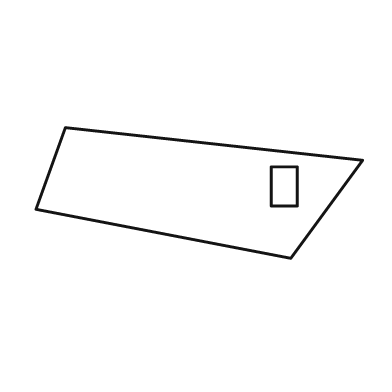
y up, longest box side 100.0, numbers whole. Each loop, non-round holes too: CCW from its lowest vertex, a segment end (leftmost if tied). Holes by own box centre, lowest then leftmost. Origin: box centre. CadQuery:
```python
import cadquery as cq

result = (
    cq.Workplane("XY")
    .moveTo(28.0, -20.0)
    .lineTo(50.0, 10.0)
    .lineTo(-41.0, 20.0)
    .lineTo(-50.0, -5.0)
    .close()
    .moveTo(22.0, -4.0)
    .lineTo(30.0, -4.0)
    .lineTo(30.0, 8.0)
    .lineTo(22.0, 8.0)
    .close()
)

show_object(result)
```